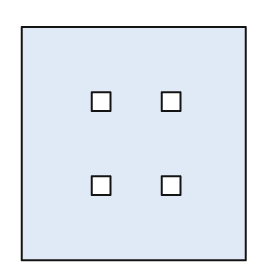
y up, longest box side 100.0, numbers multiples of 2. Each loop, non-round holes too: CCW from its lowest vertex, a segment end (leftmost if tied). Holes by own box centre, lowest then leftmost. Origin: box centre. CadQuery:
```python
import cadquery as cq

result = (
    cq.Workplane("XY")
    .moveTo(-48.0, -50.0)
    .lineTo(48.0, -50.0)
    .lineTo(48.0, 50.0)
    .lineTo(-48.0, 50.0)
    .close()
    .moveTo(-18.0, -22.0)
    .lineTo(-10.0, -22.0)
    .lineTo(-10.0, -14.0)
    .lineTo(-18.0, -14.0)
    .close()
    .moveTo(12.0, -22.0)
    .lineTo(20.0, -22.0)
    .lineTo(20.0, -14.0)
    .lineTo(12.0, -14.0)
    .close()
    .moveTo(-18.0, 14.0)
    .lineTo(-10.0, 14.0)
    .lineTo(-10.0, 22.0)
    .lineTo(-18.0, 22.0)
    .close()
    .moveTo(12.0, 14.0)
    .lineTo(20.0, 14.0)
    .lineTo(20.0, 22.0)
    .lineTo(12.0, 22.0)
    .close()
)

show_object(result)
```